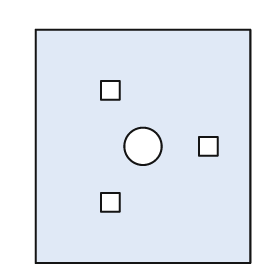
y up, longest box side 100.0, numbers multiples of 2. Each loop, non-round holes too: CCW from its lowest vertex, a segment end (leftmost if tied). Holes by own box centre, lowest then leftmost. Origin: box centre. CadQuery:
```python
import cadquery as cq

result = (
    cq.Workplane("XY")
    .moveTo(-46.0, -50.0)
    .lineTo(46.0, -50.0)
    .lineTo(46.0, 50.0)
    .lineTo(-46.0, 50.0)
    .close()
    .moveTo(-18.0, -28.0)
    .lineTo(-10.0, -28.0)
    .lineTo(-10.0, -20.0)
    .lineTo(-18.0, -20.0)
    .close()
    .moveTo(0.0, 0.0)
    .circle(8.0)
    .moveTo(24.0, -4.0)
    .lineTo(32.0, -4.0)
    .lineTo(32.0, 4.0)
    .lineTo(24.0, 4.0)
    .close()
    .moveTo(-18.0, 20.0)
    .lineTo(-10.0, 20.0)
    .lineTo(-10.0, 28.0)
    .lineTo(-18.0, 28.0)
    .close()
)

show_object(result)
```